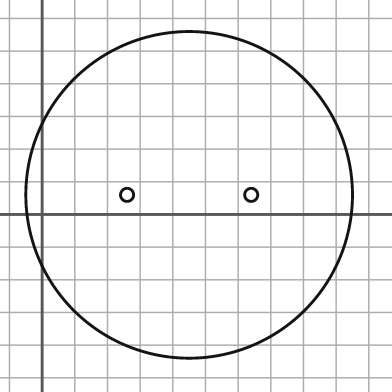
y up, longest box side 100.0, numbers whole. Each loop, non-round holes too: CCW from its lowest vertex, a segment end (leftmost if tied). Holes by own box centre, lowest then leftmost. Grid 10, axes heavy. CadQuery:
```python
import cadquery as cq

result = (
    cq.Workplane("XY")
    .moveTo(45.0, 6.0)
    .circle(50.0)
    .moveTo(26.0, 6.0)
    .circle(2.0)
    .moveTo(64.0, 6.0)
    .circle(2.0)
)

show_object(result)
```